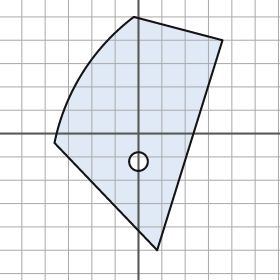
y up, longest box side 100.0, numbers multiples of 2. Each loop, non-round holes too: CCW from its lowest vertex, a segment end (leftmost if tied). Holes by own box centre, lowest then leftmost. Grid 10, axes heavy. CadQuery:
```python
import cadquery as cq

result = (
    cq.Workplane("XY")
    .moveTo(8.0, -50.0)
    .lineTo(36.0, 40.0)
    .lineTo(-2.0, 50.0)
    .threePointArc((-24.0, 26.0), (-36.0, -4.0))
    .close()
    .moveTo(0.0, -12.0)
    .circle(4.0)
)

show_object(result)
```